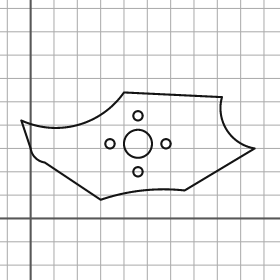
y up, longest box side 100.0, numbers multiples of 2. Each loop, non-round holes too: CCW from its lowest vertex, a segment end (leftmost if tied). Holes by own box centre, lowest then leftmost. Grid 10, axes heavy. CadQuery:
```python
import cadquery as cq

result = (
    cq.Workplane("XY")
    .moveTo(30.0, 8.0)
    .threePointArc((48.0, 12.0), (66.0, 12.0))
    .lineTo(96.0, 30.0)
    .threePointArc((84.0, 38.0), (82.0, 52.0))
    .lineTo(40.0, 54.0)
    .threePointArc((20.0, 40.0), (-4.0, 42.0))
    .lineTo(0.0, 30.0)
    .threePointArc((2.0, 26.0), (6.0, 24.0))
    .close()
    .moveTo(46.0, 20.0)
    .circle(2.0)
    .moveTo(34.0, 32.0)
    .circle(2.0)
    .moveTo(46.0, 32.0)
    .circle(6.0)
    .moveTo(58.0, 32.0)
    .circle(2.0)
    .moveTo(46.0, 44.0)
    .circle(2.0)
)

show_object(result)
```